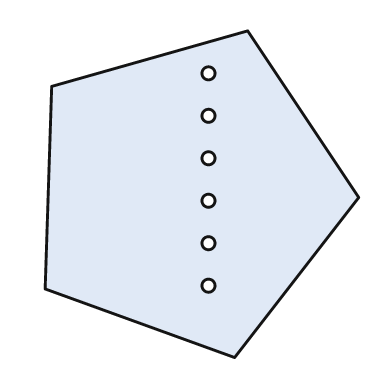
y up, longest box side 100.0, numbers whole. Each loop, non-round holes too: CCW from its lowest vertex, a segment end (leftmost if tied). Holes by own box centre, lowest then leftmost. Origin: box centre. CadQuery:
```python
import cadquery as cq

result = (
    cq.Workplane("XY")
    .moveTo(10.0, -50.0)
    .lineTo(48.0, -1.0)
    .lineTo(14.0, 50.0)
    .lineTo(-46.0, 33.0)
    .lineTo(-48.0, -29.0)
    .close()
    .moveTo(2.0, -28.0)
    .circle(2.0)
    .moveTo(2.0, -15.0)
    .circle(2.0)
    .moveTo(2.0, -2.0)
    .circle(2.0)
    .moveTo(2.0, 11.0)
    .circle(2.0)
    .moveTo(2.0, 24.0)
    .circle(2.0)
    .moveTo(2.0, 37.0)
    .circle(2.0)
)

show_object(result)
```